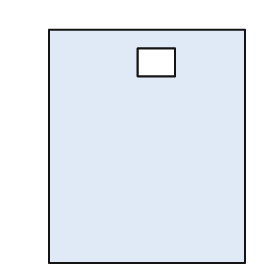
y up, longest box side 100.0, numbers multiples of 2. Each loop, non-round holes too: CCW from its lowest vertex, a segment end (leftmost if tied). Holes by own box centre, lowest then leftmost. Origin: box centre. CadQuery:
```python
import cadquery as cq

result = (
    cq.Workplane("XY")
    .moveTo(-42.0, -50.0)
    .lineTo(42.0, -50.0)
    .lineTo(42.0, 50.0)
    .lineTo(-42.0, 50.0)
    .close()
    .moveTo(-4.0, 30.0)
    .lineTo(12.0, 30.0)
    .lineTo(12.0, 42.0)
    .lineTo(-4.0, 42.0)
    .close()
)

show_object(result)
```